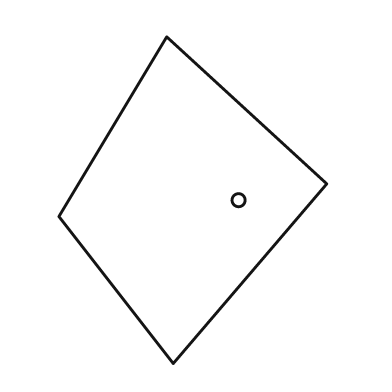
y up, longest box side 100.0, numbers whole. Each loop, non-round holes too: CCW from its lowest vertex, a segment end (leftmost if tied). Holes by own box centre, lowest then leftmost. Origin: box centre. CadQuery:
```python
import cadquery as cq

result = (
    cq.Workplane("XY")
    .moveTo(-6.0, -50.0)
    .lineTo(41.0, 5.0)
    .lineTo(-8.0, 50.0)
    .lineTo(-41.0, -5.0)
    .close()
    .moveTo(14.0, 0.0)
    .circle(2.0)
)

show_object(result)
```